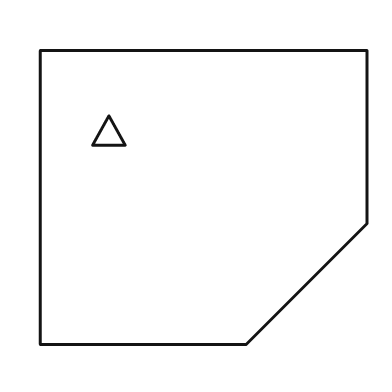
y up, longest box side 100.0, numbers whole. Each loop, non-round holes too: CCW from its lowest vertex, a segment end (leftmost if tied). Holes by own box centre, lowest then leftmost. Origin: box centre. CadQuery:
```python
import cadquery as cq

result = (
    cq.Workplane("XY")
    .moveTo(-50.0, -45.0)
    .lineTo(13.0, -45.0)
    .lineTo(50.0, -8.0)
    .lineTo(50.0, 45.0)
    .lineTo(-50.0, 45.0)
    .close()
    .moveTo(-34.0, 16.0)
    .lineTo(-24.0, 16.0)
    .lineTo(-29.0, 25.0)
    .close()
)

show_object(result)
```